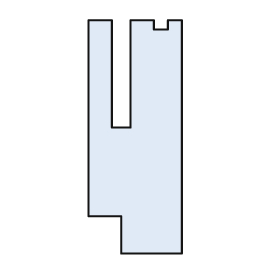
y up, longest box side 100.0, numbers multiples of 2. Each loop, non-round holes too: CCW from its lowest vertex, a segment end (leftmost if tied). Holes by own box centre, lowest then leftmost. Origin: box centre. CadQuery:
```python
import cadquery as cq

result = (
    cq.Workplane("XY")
    .moveTo(-6.0, -50.0)
    .lineTo(20.0, -50.0)
    .lineTo(20.0, 50.0)
    .lineTo(14.0, 50.0)
    .lineTo(14.0, 46.0)
    .lineTo(8.0, 46.0)
    .lineTo(8.0, 50.0)
    .lineTo(-2.0, 50.0)
    .lineTo(-2.0, 4.0)
    .lineTo(-10.0, 4.0)
    .lineTo(-10.0, 50.0)
    .lineTo(-20.0, 50.0)
    .lineTo(-20.0, -34.0)
    .lineTo(-6.0, -34.0)
    .close()
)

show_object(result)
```